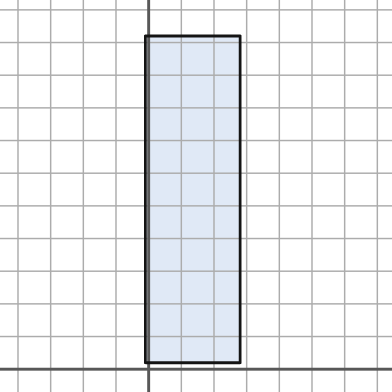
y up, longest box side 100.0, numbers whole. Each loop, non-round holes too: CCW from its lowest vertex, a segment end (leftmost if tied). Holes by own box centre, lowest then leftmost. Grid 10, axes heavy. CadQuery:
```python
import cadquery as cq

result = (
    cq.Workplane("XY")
    .moveTo(-1.0, 2.0)
    .lineTo(28.0, 2.0)
    .lineTo(28.0, 102.0)
    .lineTo(-1.0, 102.0)
    .close()
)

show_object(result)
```